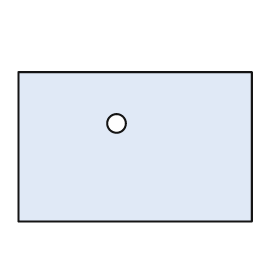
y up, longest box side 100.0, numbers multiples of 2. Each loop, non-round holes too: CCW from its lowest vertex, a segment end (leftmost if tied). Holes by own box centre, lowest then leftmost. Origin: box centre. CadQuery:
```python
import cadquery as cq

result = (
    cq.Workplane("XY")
    .moveTo(-50.0, -32.0)
    .lineTo(50.0, -32.0)
    .lineTo(50.0, 32.0)
    .lineTo(-50.0, 32.0)
    .close()
    .moveTo(-8.0, 10.0)
    .circle(4.0)
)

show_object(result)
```